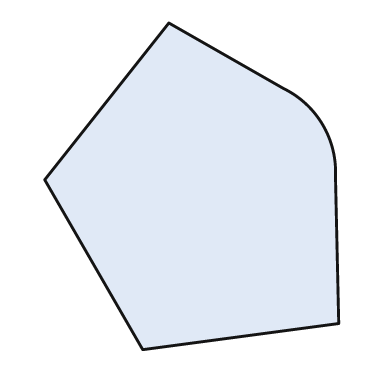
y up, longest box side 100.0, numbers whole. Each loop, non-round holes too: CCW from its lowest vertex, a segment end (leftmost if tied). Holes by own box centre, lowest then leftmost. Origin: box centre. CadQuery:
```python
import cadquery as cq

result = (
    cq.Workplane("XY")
    .moveTo(-15.0, -50.0)
    .lineTo(45.0, -42.0)
    .lineTo(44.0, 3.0)
    .threePointArc((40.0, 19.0), (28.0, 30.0))
    .lineTo(-7.0, 50.0)
    .lineTo(-45.0, 2.0)
    .close()
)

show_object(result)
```